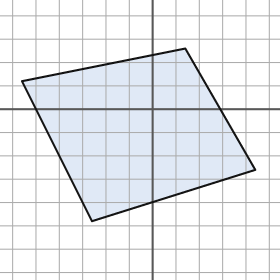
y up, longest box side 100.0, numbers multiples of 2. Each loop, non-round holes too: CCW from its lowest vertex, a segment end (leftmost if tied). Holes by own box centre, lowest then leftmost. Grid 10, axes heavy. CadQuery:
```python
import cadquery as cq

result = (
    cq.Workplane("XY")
    .moveTo(-26.0, -48.0)
    .lineTo(44.0, -26.0)
    .lineTo(14.0, 26.0)
    .lineTo(-56.0, 12.0)
    .close()
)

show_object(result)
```